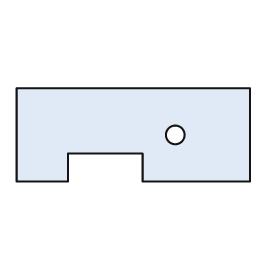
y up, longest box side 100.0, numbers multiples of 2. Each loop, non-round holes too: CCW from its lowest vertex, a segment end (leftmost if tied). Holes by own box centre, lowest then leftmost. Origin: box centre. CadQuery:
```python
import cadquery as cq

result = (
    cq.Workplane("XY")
    .moveTo(-50.0, -20.0)
    .lineTo(-28.0, -20.0)
    .lineTo(-28.0, -8.0)
    .lineTo(4.0, -8.0)
    .lineTo(4.0, -20.0)
    .lineTo(50.0, -20.0)
    .lineTo(50.0, 20.0)
    .lineTo(-50.0, 20.0)
    .close()
    .moveTo(18.0, 0.0)
    .circle(4.0)
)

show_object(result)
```